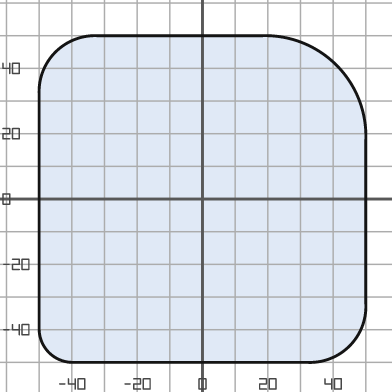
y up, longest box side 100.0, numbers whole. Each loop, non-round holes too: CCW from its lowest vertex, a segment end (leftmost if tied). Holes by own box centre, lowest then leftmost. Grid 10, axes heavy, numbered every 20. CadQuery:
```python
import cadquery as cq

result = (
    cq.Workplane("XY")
    .moveTo(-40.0, -50.0)
    .lineTo(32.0, -50.0)
    .threePointArc((45.0, -45.0), (50.0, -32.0))
    .lineTo(50.0, 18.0)
    .threePointArc((41.0, 41.0), (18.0, 50.0))
    .lineTo(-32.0, 50.0)
    .threePointArc((-45.0, 45.0), (-50.0, 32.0))
    .lineTo(-50.0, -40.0)
    .threePointArc((-47.0, -47.0), (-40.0, -50.0))
    .close()
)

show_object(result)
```